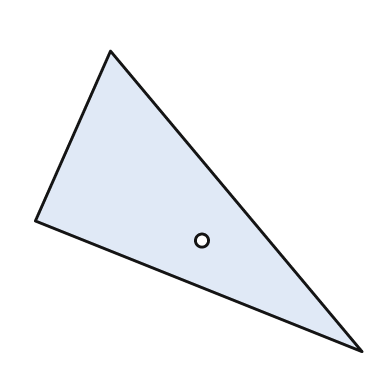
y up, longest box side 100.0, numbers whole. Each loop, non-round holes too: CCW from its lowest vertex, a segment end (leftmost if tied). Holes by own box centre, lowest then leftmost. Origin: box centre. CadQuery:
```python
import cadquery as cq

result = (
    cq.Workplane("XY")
    .moveTo(50.0, -46.0)
    .lineTo(-27.0, 46.0)
    .lineTo(-50.0, -6.0)
    .close()
    .moveTo(1.0, -12.0)
    .circle(2.0)
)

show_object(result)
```